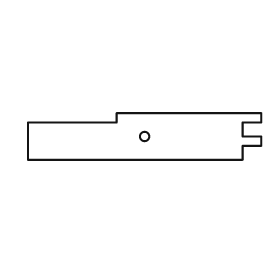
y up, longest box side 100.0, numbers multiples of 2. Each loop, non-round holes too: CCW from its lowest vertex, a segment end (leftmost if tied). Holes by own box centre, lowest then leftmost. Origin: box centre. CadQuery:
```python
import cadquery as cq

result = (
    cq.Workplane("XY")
    .moveTo(-50.0, -10.0)
    .lineTo(42.0, -10.0)
    .lineTo(42.0, -4.0)
    .lineTo(50.0, -4.0)
    .lineTo(50.0, 0.0)
    .lineTo(42.0, 0.0)
    .lineTo(42.0, 6.0)
    .lineTo(50.0, 6.0)
    .lineTo(50.0, 10.0)
    .lineTo(-12.0, 10.0)
    .lineTo(-12.0, 6.0)
    .lineTo(-50.0, 6.0)
    .close()
    .moveTo(0.0, 0.0)
    .circle(2.0)
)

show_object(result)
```